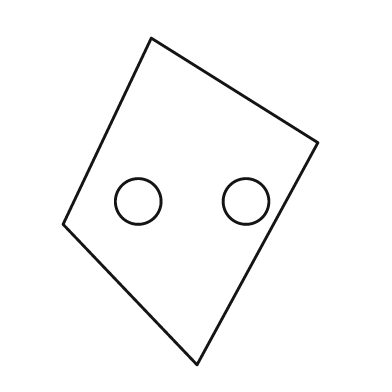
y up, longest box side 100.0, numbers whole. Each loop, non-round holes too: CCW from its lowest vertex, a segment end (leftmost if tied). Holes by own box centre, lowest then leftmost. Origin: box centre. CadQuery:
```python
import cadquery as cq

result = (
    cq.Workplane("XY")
    .moveTo(2.0, -50.0)
    .lineTo(39.0, 18.0)
    .lineTo(-12.0, 50.0)
    .lineTo(-39.0, -7.0)
    .close()
    .moveTo(-16.0, 0.0)
    .circle(7.0)
    .moveTo(17.0, 0.0)
    .circle(7.0)
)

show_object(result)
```